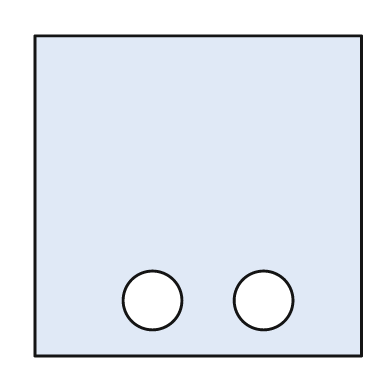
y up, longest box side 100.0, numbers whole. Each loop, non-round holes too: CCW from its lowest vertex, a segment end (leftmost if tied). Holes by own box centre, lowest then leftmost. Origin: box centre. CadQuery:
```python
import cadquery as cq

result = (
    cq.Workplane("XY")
    .moveTo(-50.0, -49.0)
    .lineTo(50.0, -49.0)
    .lineTo(50.0, 49.0)
    .lineTo(-50.0, 49.0)
    .close()
    .moveTo(-14.0, -32.0)
    .circle(9.0)
    .moveTo(20.0, -32.0)
    .circle(9.0)
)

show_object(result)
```